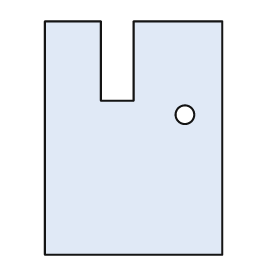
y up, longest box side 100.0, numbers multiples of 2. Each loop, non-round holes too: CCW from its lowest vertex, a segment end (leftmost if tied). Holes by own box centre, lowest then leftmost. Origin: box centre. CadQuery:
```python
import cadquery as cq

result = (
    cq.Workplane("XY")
    .moveTo(-38.0, -50.0)
    .lineTo(38.0, -50.0)
    .lineTo(38.0, 50.0)
    .lineTo(0.0, 50.0)
    .lineTo(0.0, 16.0)
    .lineTo(-14.0, 16.0)
    .lineTo(-14.0, 50.0)
    .lineTo(-38.0, 50.0)
    .close()
    .moveTo(22.0, 10.0)
    .circle(4.0)
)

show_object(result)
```